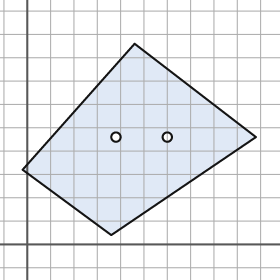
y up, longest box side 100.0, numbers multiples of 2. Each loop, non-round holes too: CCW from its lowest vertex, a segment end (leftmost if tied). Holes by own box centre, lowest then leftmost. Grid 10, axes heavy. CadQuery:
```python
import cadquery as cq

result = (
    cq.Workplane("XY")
    .moveTo(36.0, 4.0)
    .lineTo(98.0, 46.0)
    .lineTo(46.0, 86.0)
    .lineTo(-2.0, 32.0)
    .close()
    .moveTo(38.0, 46.0)
    .circle(2.0)
    .moveTo(60.0, 46.0)
    .circle(2.0)
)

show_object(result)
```